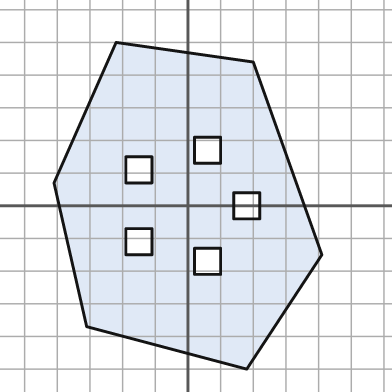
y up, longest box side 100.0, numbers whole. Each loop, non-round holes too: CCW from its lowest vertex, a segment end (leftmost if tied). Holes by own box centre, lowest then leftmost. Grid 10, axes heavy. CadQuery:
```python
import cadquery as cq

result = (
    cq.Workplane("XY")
    .moveTo(18.0, -50.0)
    .lineTo(41.0, -15.0)
    .lineTo(20.0, 44.0)
    .lineTo(-22.0, 50.0)
    .lineTo(-41.0, 7.0)
    .lineTo(-31.0, -37.0)
    .close()
    .moveTo(2.0, -21.0)
    .lineTo(10.0, -21.0)
    .lineTo(10.0, -13.0)
    .lineTo(2.0, -13.0)
    .close()
    .moveTo(-19.0, -15.0)
    .lineTo(-11.0, -15.0)
    .lineTo(-11.0, -7.0)
    .lineTo(-19.0, -7.0)
    .close()
    .moveTo(14.0, -4.0)
    .lineTo(22.0, -4.0)
    .lineTo(22.0, 4.0)
    .lineTo(14.0, 4.0)
    .close()
    .moveTo(-19.0, 7.0)
    .lineTo(-11.0, 7.0)
    .lineTo(-11.0, 15.0)
    .lineTo(-19.0, 15.0)
    .close()
    .moveTo(2.0, 13.0)
    .lineTo(10.0, 13.0)
    .lineTo(10.0, 21.0)
    .lineTo(2.0, 21.0)
    .close()
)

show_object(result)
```